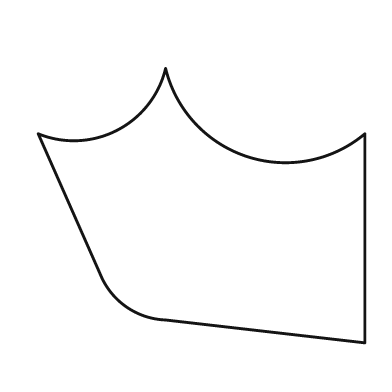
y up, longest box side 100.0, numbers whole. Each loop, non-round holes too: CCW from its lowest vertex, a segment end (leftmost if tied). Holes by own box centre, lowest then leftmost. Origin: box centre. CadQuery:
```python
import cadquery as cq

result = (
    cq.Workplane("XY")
    .moveTo(50.0, -42.0)
    .lineTo(50.0, 22.0)
    .threePointArc((14.0, 15.0), (-11.0, 42.0))
    .threePointArc((-26.0, 23.0), (-50.0, 22.0))
    .lineTo(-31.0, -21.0)
    .threePointArc((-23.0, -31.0), (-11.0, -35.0))
    .close()
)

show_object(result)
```